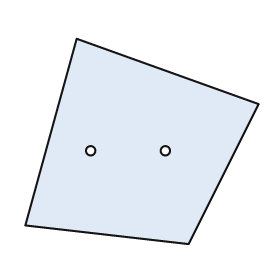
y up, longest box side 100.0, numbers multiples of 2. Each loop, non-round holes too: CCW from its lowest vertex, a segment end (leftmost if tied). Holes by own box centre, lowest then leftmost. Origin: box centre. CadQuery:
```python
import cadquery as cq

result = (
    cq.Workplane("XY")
    .moveTo(20.0, -44.0)
    .lineTo(50.0, 16.0)
    .lineTo(-28.0, 44.0)
    .lineTo(-50.0, -36.0)
    .close()
    .moveTo(-22.0, -4.0)
    .circle(2.0)
    .moveTo(10.0, -4.0)
    .circle(2.0)
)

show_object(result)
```